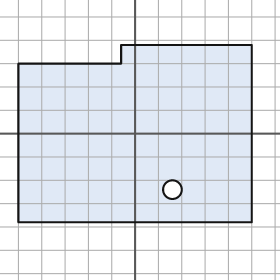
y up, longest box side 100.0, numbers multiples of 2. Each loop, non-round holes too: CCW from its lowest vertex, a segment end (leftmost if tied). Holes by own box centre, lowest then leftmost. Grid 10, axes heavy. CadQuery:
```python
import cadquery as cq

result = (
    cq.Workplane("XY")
    .moveTo(-50.0, -38.0)
    .lineTo(50.0, -38.0)
    .lineTo(50.0, 38.0)
    .lineTo(-6.0, 38.0)
    .lineTo(-6.0, 30.0)
    .lineTo(-50.0, 30.0)
    .close()
    .moveTo(16.0, -24.0)
    .circle(4.0)
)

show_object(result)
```